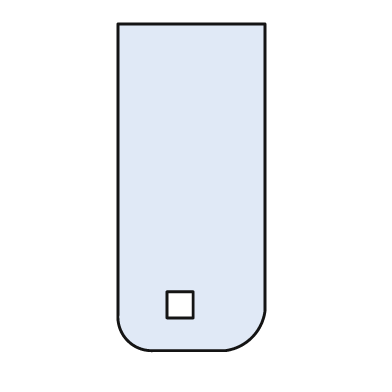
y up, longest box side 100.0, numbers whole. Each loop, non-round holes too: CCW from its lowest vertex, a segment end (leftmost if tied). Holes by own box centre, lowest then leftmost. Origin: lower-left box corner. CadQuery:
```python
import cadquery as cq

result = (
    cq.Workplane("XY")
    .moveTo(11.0, 0.0)
    .lineTo(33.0, 0.0)
    .threePointArc((41.0, 4.0), (45.0, 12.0))
    .lineTo(45.0, 100.0)
    .lineTo(0.0, 100.0)
    .lineTo(0.0, 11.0)
    .threePointArc((3.0, 3.0), (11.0, 0.0))
    .close()
    .moveTo(15.0, 10.0)
    .lineTo(23.0, 10.0)
    .lineTo(23.0, 18.0)
    .lineTo(15.0, 18.0)
    .close()
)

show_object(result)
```